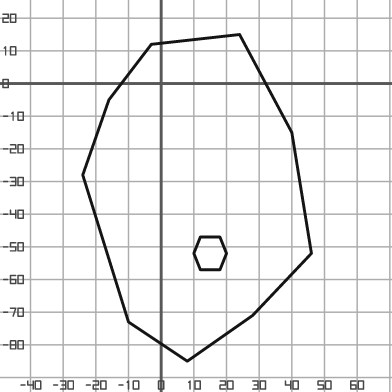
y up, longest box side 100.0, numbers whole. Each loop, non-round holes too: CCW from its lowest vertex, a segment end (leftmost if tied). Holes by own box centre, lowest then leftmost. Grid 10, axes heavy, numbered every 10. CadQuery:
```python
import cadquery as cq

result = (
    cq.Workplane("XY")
    .moveTo(8.0, -85.0)
    .lineTo(28.0, -71.0)
    .lineTo(46.0, -52.0)
    .lineTo(40.0, -15.0)
    .lineTo(24.0, 15.0)
    .lineTo(-3.0, 12.0)
    .lineTo(-16.0, -5.0)
    .lineTo(-24.0, -28.0)
    .lineTo(-10.0, -73.0)
    .close()
    .moveTo(12.0, -57.0)
    .lineTo(18.0, -57.0)
    .lineTo(20.0, -52.0)
    .lineTo(18.0, -47.0)
    .lineTo(12.0, -47.0)
    .lineTo(10.0, -52.0)
    .close()
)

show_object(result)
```